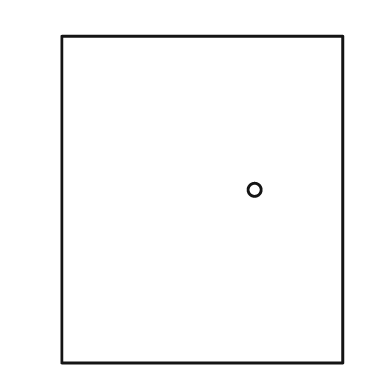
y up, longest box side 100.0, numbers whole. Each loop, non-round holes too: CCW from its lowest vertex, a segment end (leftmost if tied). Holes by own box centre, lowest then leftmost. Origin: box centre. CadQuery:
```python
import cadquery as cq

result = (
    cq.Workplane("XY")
    .moveTo(-43.0, -50.0)
    .lineTo(43.0, -50.0)
    .lineTo(43.0, 50.0)
    .lineTo(-43.0, 50.0)
    .close()
    .moveTo(16.0, 3.0)
    .circle(2.0)
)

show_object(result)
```